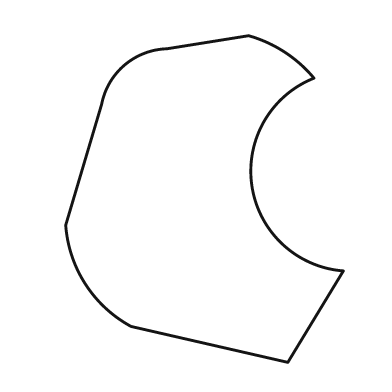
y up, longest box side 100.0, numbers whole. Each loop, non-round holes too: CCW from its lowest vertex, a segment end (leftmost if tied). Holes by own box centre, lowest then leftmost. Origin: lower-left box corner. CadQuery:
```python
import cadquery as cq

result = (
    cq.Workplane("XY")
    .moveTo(68.0, 0.0)
    .lineTo(85.0, 28.0)
    .threePointArc((57.0, 54.0), (76.0, 87.0))
    .threePointArc((67.0, 95.0), (56.0, 100.0))
    .lineTo(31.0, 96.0)
    .threePointArc((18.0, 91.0), (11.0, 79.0))
    .lineTo(0.0, 42.0)
    .threePointArc((6.0, 24.0), (20.0, 11.0))
    .close()
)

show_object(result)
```